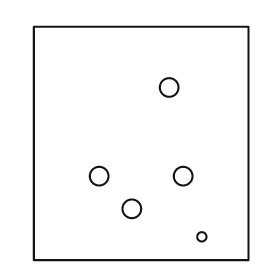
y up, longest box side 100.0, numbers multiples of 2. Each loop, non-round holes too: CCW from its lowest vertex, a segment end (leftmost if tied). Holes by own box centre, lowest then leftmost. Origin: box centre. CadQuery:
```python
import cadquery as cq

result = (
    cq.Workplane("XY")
    .moveTo(-46.0, -50.0)
    .lineTo(46.0, -50.0)
    .lineTo(46.0, 50.0)
    .lineTo(-46.0, 50.0)
    .close()
    .moveTo(26.0, -40.0)
    .circle(2.0)
    .moveTo(-4.0, -28.0)
    .circle(4.0)
    .moveTo(-18.0, -14.0)
    .circle(4.0)
    .moveTo(18.0, -14.0)
    .circle(4.0)
    .moveTo(12.0, 24.0)
    .circle(4.0)
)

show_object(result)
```